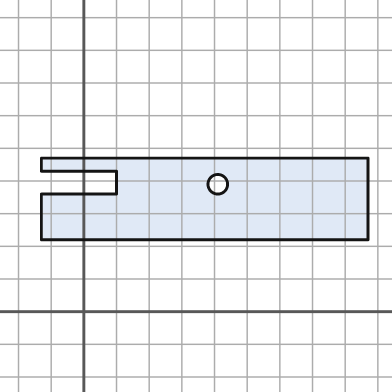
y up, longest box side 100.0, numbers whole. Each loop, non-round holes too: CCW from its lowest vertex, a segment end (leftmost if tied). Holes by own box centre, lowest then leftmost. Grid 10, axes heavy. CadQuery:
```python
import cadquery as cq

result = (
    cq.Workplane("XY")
    .moveTo(-13.0, 22.0)
    .lineTo(87.0, 22.0)
    .lineTo(87.0, 47.0)
    .lineTo(-13.0, 47.0)
    .lineTo(-13.0, 43.0)
    .lineTo(10.0, 43.0)
    .lineTo(10.0, 36.0)
    .lineTo(-13.0, 36.0)
    .close()
    .moveTo(41.0, 39.0)
    .circle(3.0)
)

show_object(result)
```